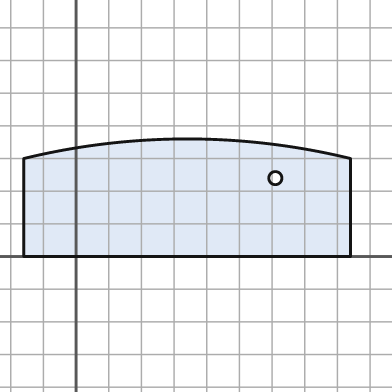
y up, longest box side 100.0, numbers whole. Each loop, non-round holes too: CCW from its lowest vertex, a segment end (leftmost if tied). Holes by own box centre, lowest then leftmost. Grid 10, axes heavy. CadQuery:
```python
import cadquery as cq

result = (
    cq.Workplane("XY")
    .moveTo(-16.0, 0.0)
    .lineTo(84.0, 0.0)
    .lineTo(84.0, 30.0)
    .threePointArc((34.0, 36.0), (-16.0, 30.0))
    .close()
    .moveTo(61.0, 24.0)
    .circle(2.0)
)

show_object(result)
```